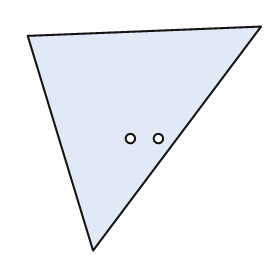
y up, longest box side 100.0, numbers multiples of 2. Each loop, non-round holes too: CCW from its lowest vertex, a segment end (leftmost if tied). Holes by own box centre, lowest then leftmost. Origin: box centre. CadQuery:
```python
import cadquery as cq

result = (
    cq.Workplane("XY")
    .moveTo(-22.0, -48.0)
    .lineTo(50.0, 48.0)
    .lineTo(-50.0, 44.0)
    .close()
    .moveTo(-6.0, 0.0)
    .circle(2.0)
    .moveTo(6.0, 0.0)
    .circle(2.0)
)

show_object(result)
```